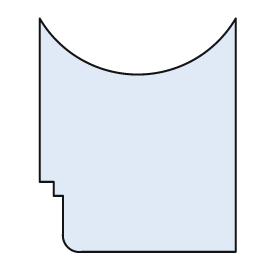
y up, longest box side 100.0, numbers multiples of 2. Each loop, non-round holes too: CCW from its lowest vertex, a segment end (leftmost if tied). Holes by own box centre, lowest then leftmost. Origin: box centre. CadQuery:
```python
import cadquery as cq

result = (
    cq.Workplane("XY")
    .moveTo(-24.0, -50.0)
    .lineTo(42.0, -50.0)
    .lineTo(42.0, 50.0)
    .threePointArc((0.0, 26.0), (-42.0, 50.0))
    .lineTo(-42.0, -20.0)
    .lineTo(-36.0, -20.0)
    .lineTo(-36.0, -26.0)
    .lineTo(-32.0, -26.0)
    .lineTo(-32.0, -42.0)
    .threePointArc((-30.0, -48.0), (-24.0, -50.0))
    .close()
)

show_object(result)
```